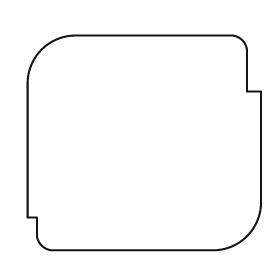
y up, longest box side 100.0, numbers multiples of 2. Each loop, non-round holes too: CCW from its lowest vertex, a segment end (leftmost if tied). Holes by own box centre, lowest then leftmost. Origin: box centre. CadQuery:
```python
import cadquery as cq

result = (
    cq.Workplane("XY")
    .moveTo(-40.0, -46.0)
    .lineTo(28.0, -46.0)
    .threePointArc((44.0, -40.0), (50.0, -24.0))
    .lineTo(50.0, 22.0)
    .lineTo(44.0, 22.0)
    .lineTo(44.0, 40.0)
    .threePointArc((42.0, 44.0), (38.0, 46.0))
    .lineTo(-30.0, 46.0)
    .threePointArc((-44.0, 40.0), (-50.0, 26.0))
    .lineTo(-50.0, -32.0)
    .lineTo(-46.0, -32.0)
    .lineTo(-46.0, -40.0)
    .threePointArc((-44.0, -44.0), (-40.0, -46.0))
    .close()
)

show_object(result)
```